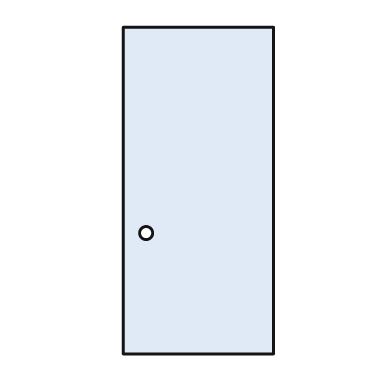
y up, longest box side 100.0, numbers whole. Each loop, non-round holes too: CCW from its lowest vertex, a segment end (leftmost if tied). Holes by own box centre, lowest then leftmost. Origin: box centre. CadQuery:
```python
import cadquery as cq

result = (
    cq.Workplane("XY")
    .moveTo(-23.0, -50.0)
    .lineTo(23.0, -50.0)
    .lineTo(23.0, 50.0)
    .lineTo(-23.0, 50.0)
    .close()
    .moveTo(-16.0, -13.0)
    .circle(2.0)
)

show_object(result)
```